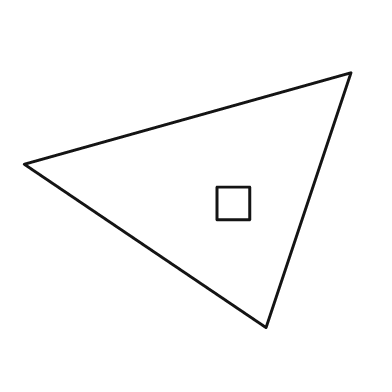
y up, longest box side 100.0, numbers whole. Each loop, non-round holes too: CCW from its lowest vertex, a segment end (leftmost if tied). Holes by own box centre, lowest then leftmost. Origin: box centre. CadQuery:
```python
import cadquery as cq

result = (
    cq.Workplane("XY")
    .moveTo(24.0, -39.0)
    .lineTo(50.0, 39.0)
    .lineTo(-50.0, 11.0)
    .close()
    .moveTo(9.0, -6.0)
    .lineTo(19.0, -6.0)
    .lineTo(19.0, 4.0)
    .lineTo(9.0, 4.0)
    .close()
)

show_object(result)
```